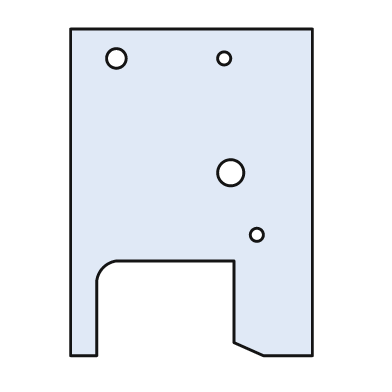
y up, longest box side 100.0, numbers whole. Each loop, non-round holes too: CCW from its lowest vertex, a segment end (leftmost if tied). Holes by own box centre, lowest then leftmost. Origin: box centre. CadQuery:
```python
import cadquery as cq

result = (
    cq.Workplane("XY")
    .moveTo(-37.0, -50.0)
    .lineTo(-29.0, -50.0)
    .lineTo(-29.0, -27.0)
    .threePointArc((-27.0, -23.0), (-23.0, -21.0))
    .lineTo(13.0, -21.0)
    .lineTo(13.0, -46.0)
    .lineTo(22.0, -50.0)
    .lineTo(37.0, -50.0)
    .lineTo(37.0, 50.0)
    .lineTo(-37.0, 50.0)
    .close()
    .moveTo(20.0, -13.0)
    .circle(2.0)
    .moveTo(12.0, 6.0)
    .circle(4.0)
    .moveTo(-23.0, 41.0)
    .circle(3.0)
    .moveTo(10.0, 41.0)
    .circle(2.0)
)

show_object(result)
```